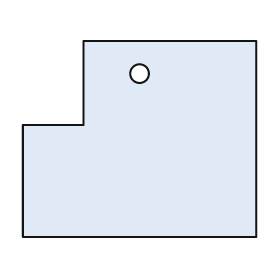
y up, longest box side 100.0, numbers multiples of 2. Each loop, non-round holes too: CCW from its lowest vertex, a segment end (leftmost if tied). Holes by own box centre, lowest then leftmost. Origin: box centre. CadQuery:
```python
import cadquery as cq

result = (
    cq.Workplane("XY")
    .moveTo(-50.0, -42.0)
    .lineTo(50.0, -42.0)
    .lineTo(50.0, 42.0)
    .lineTo(-24.0, 42.0)
    .lineTo(-24.0, 6.0)
    .lineTo(-50.0, 6.0)
    .close()
    .moveTo(0.0, 28.0)
    .circle(4.0)
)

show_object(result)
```